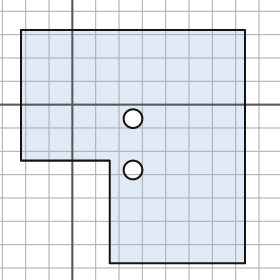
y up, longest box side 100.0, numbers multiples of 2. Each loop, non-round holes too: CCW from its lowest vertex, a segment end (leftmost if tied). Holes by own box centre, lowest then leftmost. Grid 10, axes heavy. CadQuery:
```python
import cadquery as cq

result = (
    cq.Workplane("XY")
    .moveTo(16.0, -68.0)
    .lineTo(74.0, -68.0)
    .lineTo(74.0, 32.0)
    .lineTo(-22.0, 32.0)
    .lineTo(-22.0, -24.0)
    .lineTo(16.0, -24.0)
    .close()
    .moveTo(26.0, -28.0)
    .circle(4.0)
    .moveTo(26.0, -6.0)
    .circle(4.0)
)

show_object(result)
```